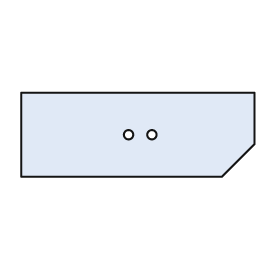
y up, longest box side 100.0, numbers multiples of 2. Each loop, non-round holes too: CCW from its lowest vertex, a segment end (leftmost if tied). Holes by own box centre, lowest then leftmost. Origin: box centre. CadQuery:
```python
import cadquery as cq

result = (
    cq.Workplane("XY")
    .moveTo(-50.0, -18.0)
    .lineTo(36.0, -18.0)
    .lineTo(50.0, -4.0)
    .lineTo(50.0, 18.0)
    .lineTo(-50.0, 18.0)
    .close()
    .moveTo(-4.0, 0.0)
    .circle(2.0)
    .moveTo(6.0, 0.0)
    .circle(2.0)
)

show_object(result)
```